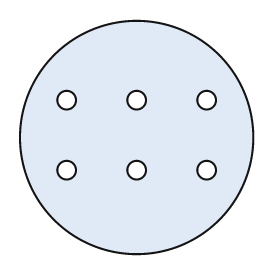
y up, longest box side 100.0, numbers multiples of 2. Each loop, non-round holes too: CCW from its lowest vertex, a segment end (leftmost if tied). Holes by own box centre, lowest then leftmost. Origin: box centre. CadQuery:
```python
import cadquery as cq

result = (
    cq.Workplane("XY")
    .moveTo(0.0, 0.0)
    .circle(50.0)
    .moveTo(-30.0, -14.0)
    .circle(4.0)
    .moveTo(0.0, -14.0)
    .circle(4.0)
    .moveTo(30.0, -14.0)
    .circle(4.0)
    .moveTo(-30.0, 16.0)
    .circle(4.0)
    .moveTo(0.0, 16.0)
    .circle(4.0)
    .moveTo(30.0, 16.0)
    .circle(4.0)
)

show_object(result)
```